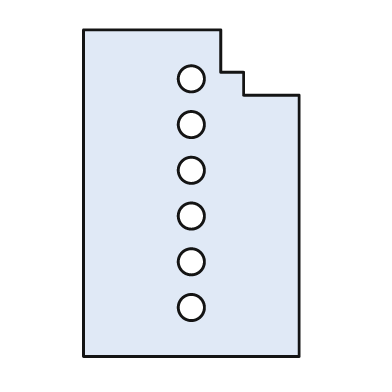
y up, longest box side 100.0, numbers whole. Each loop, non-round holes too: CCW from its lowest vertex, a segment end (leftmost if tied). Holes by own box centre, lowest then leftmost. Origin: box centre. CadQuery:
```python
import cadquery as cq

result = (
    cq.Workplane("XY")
    .moveTo(-33.0, -50.0)
    .lineTo(33.0, -50.0)
    .lineTo(33.0, 30.0)
    .lineTo(16.0, 30.0)
    .lineTo(16.0, 37.0)
    .lineTo(9.0, 37.0)
    .lineTo(9.0, 50.0)
    .lineTo(-33.0, 50.0)
    .close()
    .moveTo(0.0, -35.0)
    .circle(4.0)
    .moveTo(0.0, -21.0)
    .circle(4.0)
    .moveTo(0.0, -7.0)
    .circle(4.0)
    .moveTo(0.0, 7.0)
    .circle(4.0)
    .moveTo(0.0, 21.0)
    .circle(4.0)
    .moveTo(0.0, 35.0)
    .circle(4.0)
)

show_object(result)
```